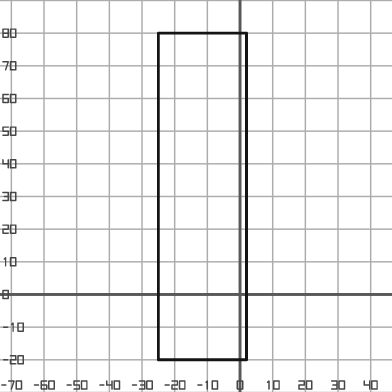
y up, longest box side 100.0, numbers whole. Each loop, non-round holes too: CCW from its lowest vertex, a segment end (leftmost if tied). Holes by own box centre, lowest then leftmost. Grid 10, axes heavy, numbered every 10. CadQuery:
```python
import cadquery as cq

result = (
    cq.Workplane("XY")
    .moveTo(-25.0, -20.0)
    .lineTo(2.0, -20.0)
    .lineTo(2.0, 80.0)
    .lineTo(-25.0, 80.0)
    .close()
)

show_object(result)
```